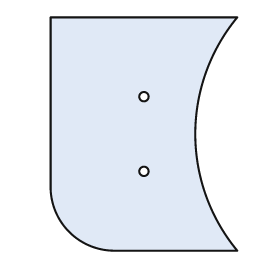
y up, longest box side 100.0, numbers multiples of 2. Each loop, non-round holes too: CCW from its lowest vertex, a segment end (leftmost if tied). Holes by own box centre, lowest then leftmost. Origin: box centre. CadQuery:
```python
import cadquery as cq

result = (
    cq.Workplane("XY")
    .moveTo(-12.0, -50.0)
    .lineTo(40.0, -50.0)
    .threePointArc((22.0, 0.0), (40.0, 50.0))
    .lineTo(-40.0, 50.0)
    .lineTo(-40.0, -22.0)
    .threePointArc((-32.0, -42.0), (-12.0, -50.0))
    .close()
    .moveTo(0.0, -16.0)
    .circle(2.0)
    .moveTo(0.0, 16.0)
    .circle(2.0)
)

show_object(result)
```